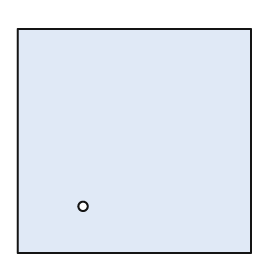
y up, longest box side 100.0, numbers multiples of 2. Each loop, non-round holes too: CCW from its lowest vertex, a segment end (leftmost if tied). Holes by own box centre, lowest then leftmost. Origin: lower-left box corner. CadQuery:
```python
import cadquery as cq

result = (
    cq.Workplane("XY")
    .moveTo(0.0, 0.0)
    .lineTo(100.0, 0.0)
    .lineTo(100.0, 96.0)
    .lineTo(0.0, 96.0)
    .close()
    .moveTo(28.0, 20.0)
    .circle(2.0)
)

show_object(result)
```